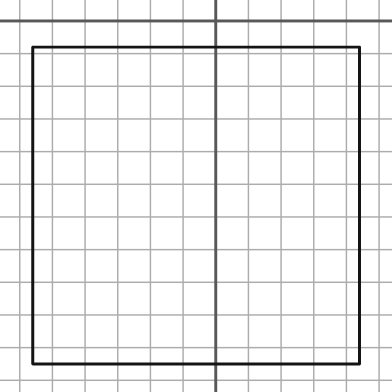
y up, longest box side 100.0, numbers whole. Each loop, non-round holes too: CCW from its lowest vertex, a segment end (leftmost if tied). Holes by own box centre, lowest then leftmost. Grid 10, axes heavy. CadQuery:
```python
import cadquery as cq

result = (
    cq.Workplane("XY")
    .moveTo(-56.0, -105.0)
    .lineTo(44.0, -105.0)
    .lineTo(44.0, -8.0)
    .lineTo(-56.0, -8.0)
    .close()
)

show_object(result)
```